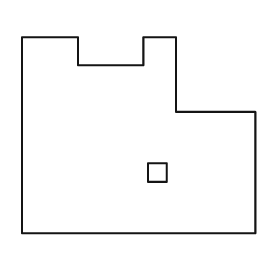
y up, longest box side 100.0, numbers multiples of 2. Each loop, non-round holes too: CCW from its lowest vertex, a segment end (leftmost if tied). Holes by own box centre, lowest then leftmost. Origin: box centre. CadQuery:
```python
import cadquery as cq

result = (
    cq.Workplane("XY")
    .moveTo(-50.0, -42.0)
    .lineTo(50.0, -42.0)
    .lineTo(50.0, 10.0)
    .lineTo(16.0, 10.0)
    .lineTo(16.0, 42.0)
    .lineTo(2.0, 42.0)
    .lineTo(2.0, 30.0)
    .lineTo(-26.0, 30.0)
    .lineTo(-26.0, 42.0)
    .lineTo(-50.0, 42.0)
    .close()
    .moveTo(4.0, -20.0)
    .lineTo(12.0, -20.0)
    .lineTo(12.0, -12.0)
    .lineTo(4.0, -12.0)
    .close()
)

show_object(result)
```